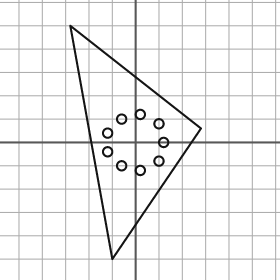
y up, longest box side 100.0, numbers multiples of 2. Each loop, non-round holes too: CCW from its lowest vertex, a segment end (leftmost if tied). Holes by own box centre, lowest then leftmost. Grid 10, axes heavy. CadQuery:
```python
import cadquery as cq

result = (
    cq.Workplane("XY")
    .moveTo(-10.0, -50.0)
    .lineTo(28.0, 6.0)
    .lineTo(-28.0, 50.0)
    .close()
    .moveTo(2.0, -12.0)
    .circle(2.0)
    .moveTo(-6.0, -10.0)
    .circle(2.0)
    .moveTo(10.0, -8.0)
    .circle(2.0)
    .moveTo(-12.0, -4.0)
    .circle(2.0)
    .moveTo(12.0, 0.0)
    .circle(2.0)
    .moveTo(-12.0, 4.0)
    .circle(2.0)
    .moveTo(10.0, 8.0)
    .circle(2.0)
    .moveTo(-6.0, 10.0)
    .circle(2.0)
    .moveTo(2.0, 12.0)
    .circle(2.0)
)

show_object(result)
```